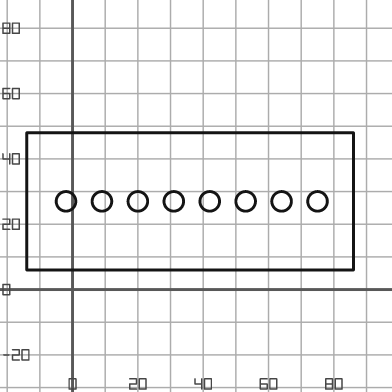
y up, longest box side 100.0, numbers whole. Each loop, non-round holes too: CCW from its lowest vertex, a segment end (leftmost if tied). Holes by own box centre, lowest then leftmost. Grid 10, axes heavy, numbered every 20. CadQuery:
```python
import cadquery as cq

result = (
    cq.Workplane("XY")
    .moveTo(-14.0, 6.0)
    .lineTo(86.0, 6.0)
    .lineTo(86.0, 48.0)
    .lineTo(-14.0, 48.0)
    .close()
    .moveTo(-2.0, 27.0)
    .circle(3.0)
    .moveTo(9.0, 27.0)
    .circle(3.0)
    .moveTo(20.0, 27.0)
    .circle(3.0)
    .moveTo(31.0, 27.0)
    .circle(3.0)
    .moveTo(42.0, 27.0)
    .circle(3.0)
    .moveTo(53.0, 27.0)
    .circle(3.0)
    .moveTo(64.0, 27.0)
    .circle(3.0)
    .moveTo(75.0, 27.0)
    .circle(3.0)
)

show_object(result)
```